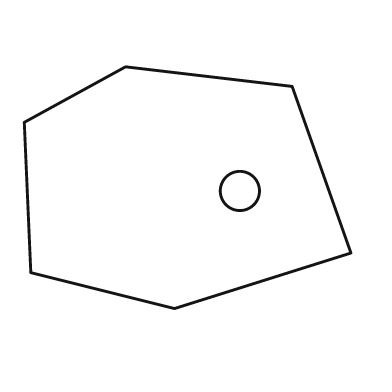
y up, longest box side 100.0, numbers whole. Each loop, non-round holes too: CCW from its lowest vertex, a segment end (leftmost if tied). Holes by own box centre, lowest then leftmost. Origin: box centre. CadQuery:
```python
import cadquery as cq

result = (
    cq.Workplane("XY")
    .moveTo(-4.0, -37.0)
    .lineTo(50.0, -20.0)
    .lineTo(32.0, 31.0)
    .lineTo(-19.0, 37.0)
    .lineTo(-50.0, 20.0)
    .lineTo(-48.0, -26.0)
    .close()
    .moveTo(16.0, -1.0)
    .circle(6.0)
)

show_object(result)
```